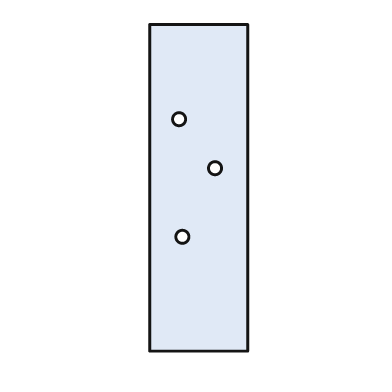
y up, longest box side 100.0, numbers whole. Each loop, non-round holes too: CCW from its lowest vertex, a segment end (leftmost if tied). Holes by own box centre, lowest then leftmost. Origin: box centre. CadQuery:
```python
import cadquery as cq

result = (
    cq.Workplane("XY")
    .moveTo(-15.0, -50.0)
    .lineTo(15.0, -50.0)
    .lineTo(15.0, 50.0)
    .lineTo(-15.0, 50.0)
    .close()
    .moveTo(-5.0, -15.0)
    .circle(2.0)
    .moveTo(5.0, 6.0)
    .circle(2.0)
    .moveTo(-6.0, 21.0)
    .circle(2.0)
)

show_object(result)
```